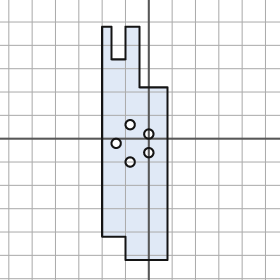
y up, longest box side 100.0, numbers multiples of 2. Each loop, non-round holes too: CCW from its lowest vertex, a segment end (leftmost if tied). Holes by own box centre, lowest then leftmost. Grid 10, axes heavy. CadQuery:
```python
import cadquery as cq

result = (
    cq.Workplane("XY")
    .moveTo(-10.0, -52.0)
    .lineTo(8.0, -52.0)
    .lineTo(8.0, 22.0)
    .lineTo(-4.0, 22.0)
    .lineTo(-4.0, 48.0)
    .lineTo(-10.0, 48.0)
    .lineTo(-10.0, 34.0)
    .lineTo(-16.0, 34.0)
    .lineTo(-16.0, 48.0)
    .lineTo(-20.0, 48.0)
    .lineTo(-20.0, -42.0)
    .lineTo(-10.0, -42.0)
    .close()
    .moveTo(-8.0, -10.0)
    .circle(2.0)
    .moveTo(0.0, -6.0)
    .circle(2.0)
    .moveTo(-14.0, -2.0)
    .circle(2.0)
    .moveTo(0.0, 2.0)
    .circle(2.0)
    .moveTo(-8.0, 6.0)
    .circle(2.0)
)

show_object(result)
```